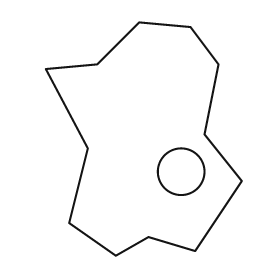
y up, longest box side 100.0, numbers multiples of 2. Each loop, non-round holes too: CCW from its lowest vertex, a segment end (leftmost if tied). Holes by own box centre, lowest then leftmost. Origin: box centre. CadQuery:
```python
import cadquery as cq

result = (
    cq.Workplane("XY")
    .moveTo(-12.0, -50.0)
    .lineTo(2.0, -42.0)
    .lineTo(22.0, -48.0)
    .lineTo(42.0, -18.0)
    .lineTo(26.0, 2.0)
    .lineTo(32.0, 32.0)
    .lineTo(20.0, 48.0)
    .lineTo(-2.0, 50.0)
    .lineTo(-20.0, 32.0)
    .lineTo(-42.0, 30.0)
    .lineTo(-24.0, -4.0)
    .lineTo(-32.0, -36.0)
    .close()
    .moveTo(16.0, -14.0)
    .circle(10.0)
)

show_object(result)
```